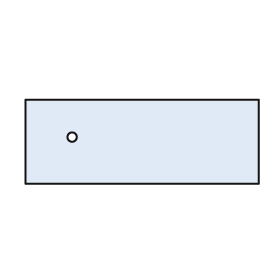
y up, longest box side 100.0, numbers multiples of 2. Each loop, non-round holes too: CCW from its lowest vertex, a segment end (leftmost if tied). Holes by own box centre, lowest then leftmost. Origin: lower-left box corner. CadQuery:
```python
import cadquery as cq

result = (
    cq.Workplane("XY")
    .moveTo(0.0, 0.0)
    .lineTo(100.0, 0.0)
    .lineTo(100.0, 36.0)
    .lineTo(0.0, 36.0)
    .close()
    .moveTo(20.0, 20.0)
    .circle(2.0)
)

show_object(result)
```